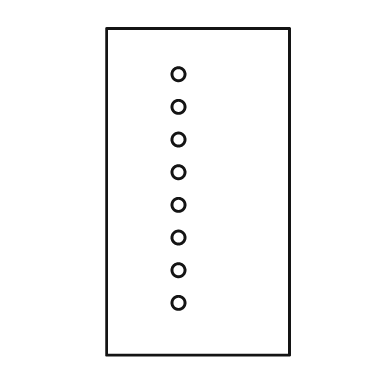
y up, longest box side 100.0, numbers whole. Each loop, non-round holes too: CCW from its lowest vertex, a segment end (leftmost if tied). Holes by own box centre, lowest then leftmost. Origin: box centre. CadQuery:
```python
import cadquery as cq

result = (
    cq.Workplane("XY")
    .moveTo(-28.0, -50.0)
    .lineTo(28.0, -50.0)
    .lineTo(28.0, 50.0)
    .lineTo(-28.0, 50.0)
    .close()
    .moveTo(-6.0, -34.0)
    .circle(2.0)
    .moveTo(-6.0, -24.0)
    .circle(2.0)
    .moveTo(-6.0, -14.0)
    .circle(2.0)
    .moveTo(-6.0, -4.0)
    .circle(2.0)
    .moveTo(-6.0, 6.0)
    .circle(2.0)
    .moveTo(-6.0, 16.0)
    .circle(2.0)
    .moveTo(-6.0, 26.0)
    .circle(2.0)
    .moveTo(-6.0, 36.0)
    .circle(2.0)
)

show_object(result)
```